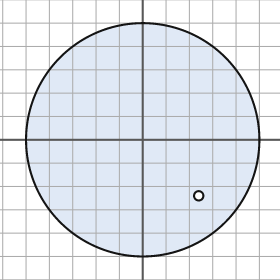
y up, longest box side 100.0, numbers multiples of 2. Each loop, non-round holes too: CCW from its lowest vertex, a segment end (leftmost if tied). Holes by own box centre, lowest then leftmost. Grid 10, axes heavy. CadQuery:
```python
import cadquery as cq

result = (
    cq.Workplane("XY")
    .moveTo(0.0, 0.0)
    .circle(50.0)
    .moveTo(24.0, -24.0)
    .circle(2.0)
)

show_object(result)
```